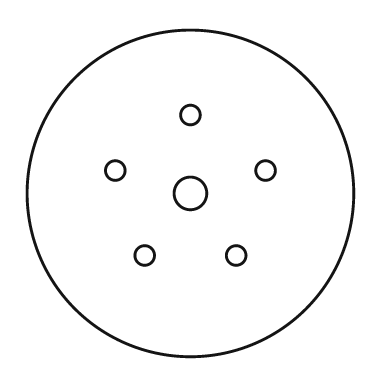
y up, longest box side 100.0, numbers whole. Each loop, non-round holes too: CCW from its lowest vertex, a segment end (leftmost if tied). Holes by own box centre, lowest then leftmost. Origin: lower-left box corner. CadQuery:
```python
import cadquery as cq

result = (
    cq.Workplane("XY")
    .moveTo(50.0, 50.0)
    .circle(50.0)
    .moveTo(36.0, 31.0)
    .circle(3.0)
    .moveTo(64.0, 31.0)
    .circle(3.0)
    .moveTo(50.0, 50.0)
    .circle(5.0)
    .moveTo(27.0, 57.0)
    .circle(3.0)
    .moveTo(73.0, 57.0)
    .circle(3.0)
    .moveTo(50.0, 74.0)
    .circle(3.0)
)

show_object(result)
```